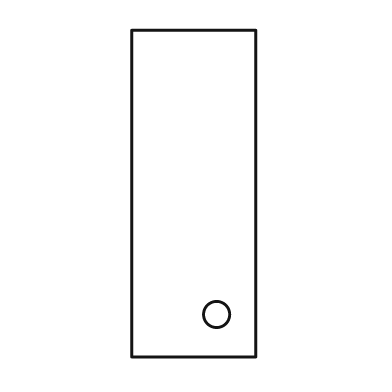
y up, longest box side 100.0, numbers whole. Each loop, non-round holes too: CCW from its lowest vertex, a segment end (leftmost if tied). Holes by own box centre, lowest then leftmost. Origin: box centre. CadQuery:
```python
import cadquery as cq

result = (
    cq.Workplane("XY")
    .moveTo(-19.0, -50.0)
    .lineTo(19.0, -50.0)
    .lineTo(19.0, 50.0)
    .lineTo(-19.0, 50.0)
    .close()
    .moveTo(7.0, -37.0)
    .circle(4.0)
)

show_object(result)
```